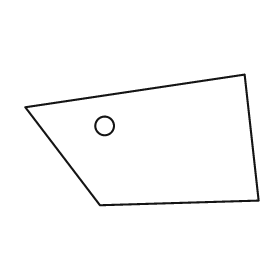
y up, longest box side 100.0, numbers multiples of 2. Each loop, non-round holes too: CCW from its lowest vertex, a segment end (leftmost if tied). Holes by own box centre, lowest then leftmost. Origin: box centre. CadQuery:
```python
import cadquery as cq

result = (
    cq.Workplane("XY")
    .moveTo(-18.0, -28.0)
    .lineTo(50.0, -26.0)
    .lineTo(44.0, 28.0)
    .lineTo(-50.0, 14.0)
    .close()
    .moveTo(-16.0, 6.0)
    .circle(4.0)
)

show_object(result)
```